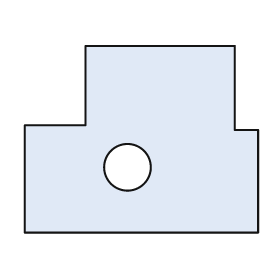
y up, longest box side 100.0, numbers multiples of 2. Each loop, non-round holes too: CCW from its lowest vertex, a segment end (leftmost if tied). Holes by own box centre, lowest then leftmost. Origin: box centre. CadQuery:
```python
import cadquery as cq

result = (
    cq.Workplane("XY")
    .moveTo(-50.0, -40.0)
    .lineTo(50.0, -40.0)
    .lineTo(50.0, 4.0)
    .lineTo(40.0, 4.0)
    .lineTo(40.0, 40.0)
    .lineTo(-24.0, 40.0)
    .lineTo(-24.0, 6.0)
    .lineTo(-50.0, 6.0)
    .close()
    .moveTo(-6.0, -12.0)
    .circle(10.0)
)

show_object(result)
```